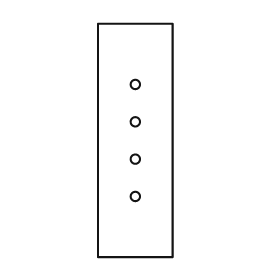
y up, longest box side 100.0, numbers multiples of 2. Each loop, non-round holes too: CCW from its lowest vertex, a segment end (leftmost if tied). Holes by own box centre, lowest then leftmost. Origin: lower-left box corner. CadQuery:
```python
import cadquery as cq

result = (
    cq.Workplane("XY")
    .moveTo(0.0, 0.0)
    .lineTo(32.0, 0.0)
    .lineTo(32.0, 100.0)
    .lineTo(0.0, 100.0)
    .close()
    .moveTo(16.0, 26.0)
    .circle(2.0)
    .moveTo(16.0, 42.0)
    .circle(2.0)
    .moveTo(16.0, 58.0)
    .circle(2.0)
    .moveTo(16.0, 74.0)
    .circle(2.0)
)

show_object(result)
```